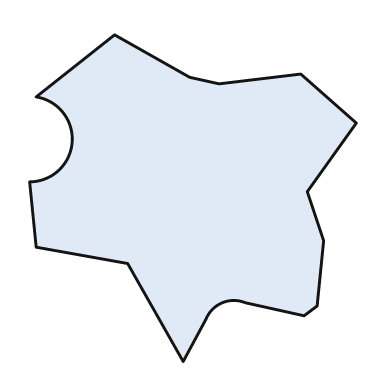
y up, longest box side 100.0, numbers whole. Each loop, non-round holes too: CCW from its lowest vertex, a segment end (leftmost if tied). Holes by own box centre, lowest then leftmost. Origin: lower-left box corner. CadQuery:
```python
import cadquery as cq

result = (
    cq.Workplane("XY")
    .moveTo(47.0, 0.0)
    .lineTo(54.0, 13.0)
    .threePointArc((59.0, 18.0), (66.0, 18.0))
    .lineTo(84.0, 14.0)
    .lineTo(88.0, 17.0)
    .lineTo(90.0, 37.0)
    .lineTo(85.0, 52.0)
    .lineTo(100.0, 73.0)
    .lineTo(83.0, 88.0)
    .lineTo(58.0, 85.0)
    .lineTo(49.0, 87.0)
    .lineTo(26.0, 100.0)
    .lineTo(2.0, 81.0)
    .threePointArc((13.0, 67.0), (0.0, 55.0))
    .lineTo(2.0, 35.0)
    .lineTo(30.0, 30.0)
    .close()
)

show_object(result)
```